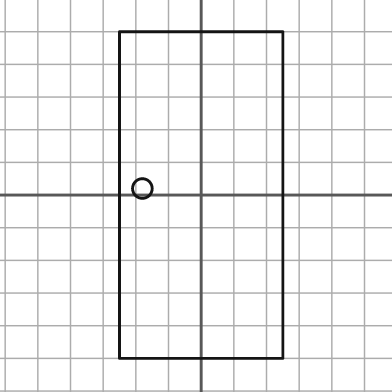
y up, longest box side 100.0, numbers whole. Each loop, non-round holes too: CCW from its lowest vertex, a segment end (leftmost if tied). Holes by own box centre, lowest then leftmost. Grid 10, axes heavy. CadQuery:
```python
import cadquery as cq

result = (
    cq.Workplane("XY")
    .moveTo(-25.0, -50.0)
    .lineTo(25.0, -50.0)
    .lineTo(25.0, 50.0)
    .lineTo(-25.0, 50.0)
    .close()
    .moveTo(-18.0, 2.0)
    .circle(3.0)
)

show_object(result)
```